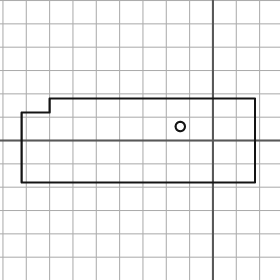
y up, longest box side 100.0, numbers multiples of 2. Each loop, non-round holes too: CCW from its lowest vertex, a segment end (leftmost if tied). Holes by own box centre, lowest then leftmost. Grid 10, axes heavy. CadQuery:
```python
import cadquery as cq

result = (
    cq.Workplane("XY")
    .moveTo(-82.0, -18.0)
    .lineTo(18.0, -18.0)
    .lineTo(18.0, 18.0)
    .lineTo(-70.0, 18.0)
    .lineTo(-70.0, 12.0)
    .lineTo(-82.0, 12.0)
    .close()
    .moveTo(-14.0, 6.0)
    .circle(2.0)
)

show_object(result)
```